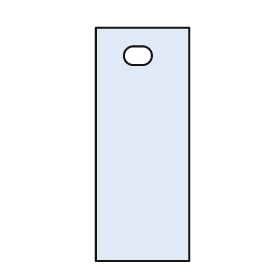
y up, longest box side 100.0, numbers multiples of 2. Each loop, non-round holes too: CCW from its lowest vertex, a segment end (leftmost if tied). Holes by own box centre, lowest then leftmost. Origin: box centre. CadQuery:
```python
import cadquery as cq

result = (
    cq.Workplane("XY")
    .moveTo(-20.0, -50.0)
    .lineTo(20.0, -50.0)
    .lineTo(20.0, 50.0)
    .lineTo(-20.0, 50.0)
    .close()
    .moveTo(-4.0, 34.0)
    .lineTo(0.0, 34.0)
    .threePointArc((4.0, 38.0), (0.0, 42.0))
    .lineTo(-4.0, 42.0)
    .threePointArc((-8.0, 38.0), (-4.0, 34.0))
    .close()
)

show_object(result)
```